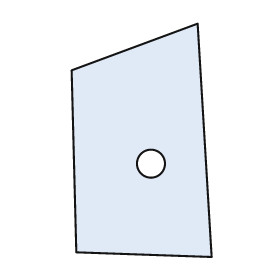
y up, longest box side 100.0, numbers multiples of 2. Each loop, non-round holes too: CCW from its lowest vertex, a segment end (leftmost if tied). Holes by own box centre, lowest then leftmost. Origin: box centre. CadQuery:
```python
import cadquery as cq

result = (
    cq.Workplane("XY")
    .moveTo(30.0, -50.0)
    .lineTo(24.0, 50.0)
    .lineTo(-30.0, 30.0)
    .lineTo(-28.0, -48.0)
    .close()
    .moveTo(4.0, -10.0)
    .circle(6.0)
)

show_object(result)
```